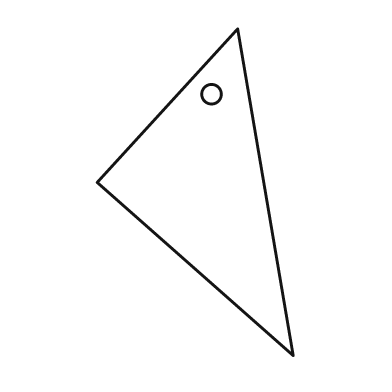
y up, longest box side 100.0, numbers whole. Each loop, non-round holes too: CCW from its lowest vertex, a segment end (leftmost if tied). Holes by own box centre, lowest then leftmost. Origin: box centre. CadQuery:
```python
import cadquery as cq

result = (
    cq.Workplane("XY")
    .moveTo(30.0, -50.0)
    .lineTo(13.0, 50.0)
    .lineTo(-30.0, 3.0)
    .close()
    .moveTo(5.0, 30.0)
    .circle(3.0)
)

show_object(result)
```